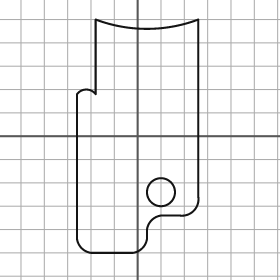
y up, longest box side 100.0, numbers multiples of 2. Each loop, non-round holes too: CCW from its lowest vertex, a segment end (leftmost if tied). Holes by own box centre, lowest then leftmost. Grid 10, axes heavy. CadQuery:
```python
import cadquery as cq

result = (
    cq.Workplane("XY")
    .moveTo(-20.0, -50.0)
    .lineTo(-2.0, -50.0)
    .threePointArc((2.0, -48.0), (4.0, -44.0))
    .lineTo(4.0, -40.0)
    .threePointArc((6.0, -36.0), (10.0, -34.0))
    .lineTo(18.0, -34.0)
    .threePointArc((24.0, -32.0), (26.0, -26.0))
    .lineTo(26.0, 50.0)
    .threePointArc((4.0, 46.0), (-18.0, 50.0))
    .lineTo(-18.0, 18.0)
    .threePointArc((-22.0, 20.0), (-26.0, 18.0))
    .lineTo(-26.0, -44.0)
    .threePointArc((-24.0, -48.0), (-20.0, -50.0))
    .close()
    .moveTo(10.0, -24.0)
    .circle(6.0)
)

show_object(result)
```